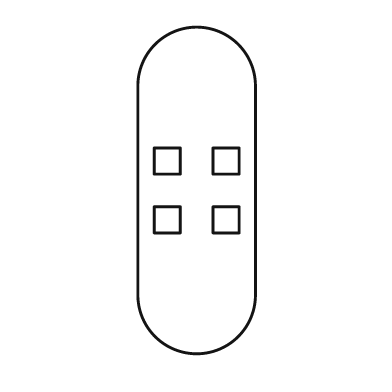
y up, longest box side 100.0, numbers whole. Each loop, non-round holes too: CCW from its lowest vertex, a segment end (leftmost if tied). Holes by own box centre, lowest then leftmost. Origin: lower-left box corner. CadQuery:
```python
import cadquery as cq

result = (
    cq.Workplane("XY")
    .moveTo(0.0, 18.0)
    .threePointArc((18.0, 0.0), (36.0, 18.0))
    .lineTo(36.0, 82.0)
    .threePointArc((18.0, 100.0), (0.0, 82.0))
    .close()
    .moveTo(5.0, 37.0)
    .lineTo(13.0, 37.0)
    .lineTo(13.0, 45.0)
    .lineTo(5.0, 45.0)
    .close()
    .moveTo(23.0, 37.0)
    .lineTo(31.0, 37.0)
    .lineTo(31.0, 45.0)
    .lineTo(23.0, 45.0)
    .close()
    .moveTo(5.0, 55.0)
    .lineTo(13.0, 55.0)
    .lineTo(13.0, 63.0)
    .lineTo(5.0, 63.0)
    .close()
    .moveTo(23.0, 55.0)
    .lineTo(31.0, 55.0)
    .lineTo(31.0, 63.0)
    .lineTo(23.0, 63.0)
    .close()
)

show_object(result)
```